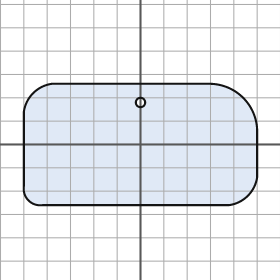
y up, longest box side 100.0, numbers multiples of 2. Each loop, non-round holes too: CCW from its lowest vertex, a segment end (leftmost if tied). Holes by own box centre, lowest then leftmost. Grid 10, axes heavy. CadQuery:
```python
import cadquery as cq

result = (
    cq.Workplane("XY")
    .moveTo(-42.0, -26.0)
    .lineTo(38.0, -26.0)
    .threePointArc((46.0, -22.0), (50.0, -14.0))
    .lineTo(50.0, 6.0)
    .threePointArc((44.0, 20.0), (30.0, 26.0))
    .lineTo(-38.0, 26.0)
    .threePointArc((-46.0, 22.0), (-50.0, 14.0))
    .lineTo(-50.0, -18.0)
    .threePointArc((-48.0, -24.0), (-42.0, -26.0))
    .close()
    .moveTo(0.0, 18.0)
    .circle(2.0)
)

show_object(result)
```